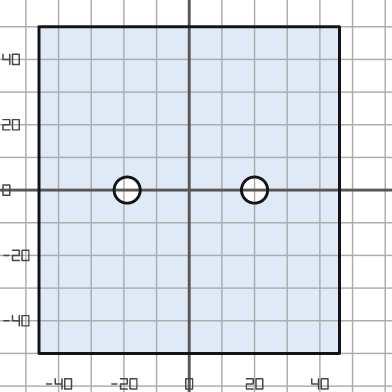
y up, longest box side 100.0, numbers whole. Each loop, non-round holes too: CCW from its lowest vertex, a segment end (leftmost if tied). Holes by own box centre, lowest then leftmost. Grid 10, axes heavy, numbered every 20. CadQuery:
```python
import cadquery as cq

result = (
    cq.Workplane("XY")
    .moveTo(-46.0, -50.0)
    .lineTo(46.0, -50.0)
    .lineTo(46.0, 50.0)
    .lineTo(-46.0, 50.0)
    .close()
    .moveTo(-19.0, 0.0)
    .circle(4.0)
    .moveTo(20.0, 0.0)
    .circle(4.0)
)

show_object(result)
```